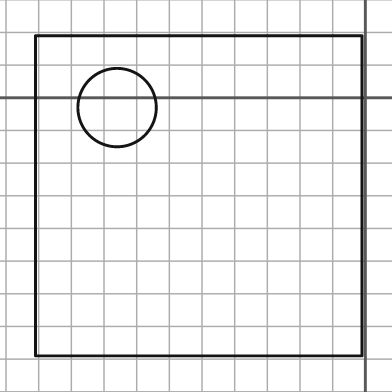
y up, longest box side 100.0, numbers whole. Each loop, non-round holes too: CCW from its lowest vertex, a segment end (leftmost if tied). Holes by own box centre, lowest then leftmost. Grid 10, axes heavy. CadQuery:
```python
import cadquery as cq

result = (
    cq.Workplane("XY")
    .moveTo(-101.0, -79.0)
    .lineTo(-1.0, -79.0)
    .lineTo(-1.0, 19.0)
    .lineTo(-101.0, 19.0)
    .close()
    .moveTo(-76.0, -3.0)
    .circle(12.0)
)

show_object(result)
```